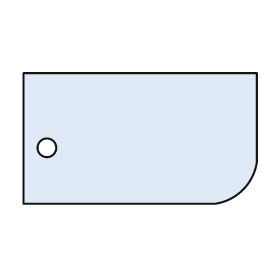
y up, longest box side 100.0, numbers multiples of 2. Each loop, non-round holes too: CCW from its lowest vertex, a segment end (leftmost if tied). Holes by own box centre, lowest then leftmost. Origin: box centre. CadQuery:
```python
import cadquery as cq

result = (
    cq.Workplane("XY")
    .moveTo(-50.0, -28.0)
    .lineTo(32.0, -28.0)
    .threePointArc((44.0, -22.0), (50.0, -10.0))
    .lineTo(50.0, 28.0)
    .lineTo(-50.0, 28.0)
    .close()
    .moveTo(-40.0, -4.0)
    .circle(4.0)
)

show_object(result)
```